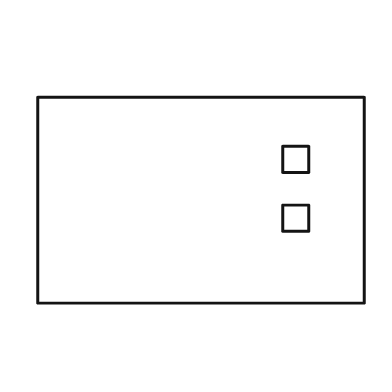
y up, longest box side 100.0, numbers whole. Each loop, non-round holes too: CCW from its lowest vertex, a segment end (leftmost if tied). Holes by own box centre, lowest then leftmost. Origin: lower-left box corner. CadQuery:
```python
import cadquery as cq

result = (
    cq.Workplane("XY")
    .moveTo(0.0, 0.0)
    .lineTo(100.0, 0.0)
    .lineTo(100.0, 63.0)
    .lineTo(0.0, 63.0)
    .close()
    .moveTo(75.0, 22.0)
    .lineTo(83.0, 22.0)
    .lineTo(83.0, 30.0)
    .lineTo(75.0, 30.0)
    .close()
    .moveTo(75.0, 40.0)
    .lineTo(83.0, 40.0)
    .lineTo(83.0, 48.0)
    .lineTo(75.0, 48.0)
    .close()
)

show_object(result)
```